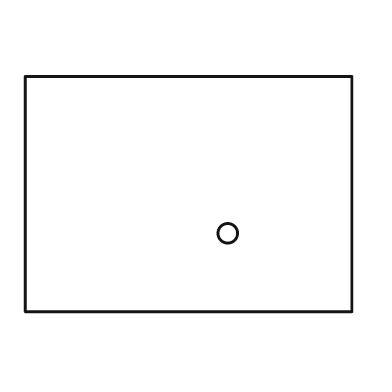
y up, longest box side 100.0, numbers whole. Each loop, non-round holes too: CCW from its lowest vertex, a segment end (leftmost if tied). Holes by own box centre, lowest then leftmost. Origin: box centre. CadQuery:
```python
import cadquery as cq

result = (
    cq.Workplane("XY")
    .moveTo(-50.0, -36.0)
    .lineTo(50.0, -36.0)
    .lineTo(50.0, 36.0)
    .lineTo(-50.0, 36.0)
    .close()
    .moveTo(12.0, -12.0)
    .circle(3.0)
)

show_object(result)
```